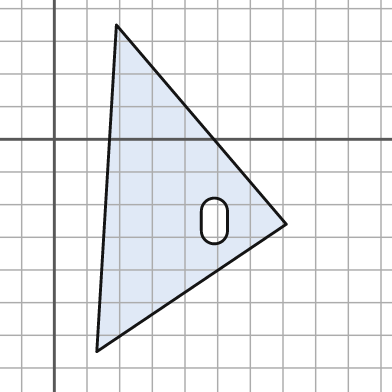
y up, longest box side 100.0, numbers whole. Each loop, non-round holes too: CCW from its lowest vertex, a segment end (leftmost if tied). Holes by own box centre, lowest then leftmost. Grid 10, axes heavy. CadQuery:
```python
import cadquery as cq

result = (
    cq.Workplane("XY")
    .moveTo(13.0, -65.0)
    .lineTo(71.0, -26.0)
    .lineTo(19.0, 35.0)
    .close()
    .moveTo(45.0, -28.0)
    .threePointArc((49.0, -32.0), (53.0, -28.0))
    .lineTo(53.0, -22.0)
    .threePointArc((49.0, -18.0), (45.0, -22.0))
    .close()
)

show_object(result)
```